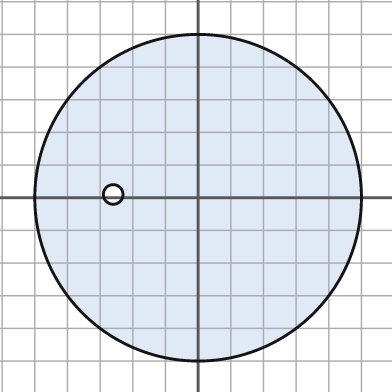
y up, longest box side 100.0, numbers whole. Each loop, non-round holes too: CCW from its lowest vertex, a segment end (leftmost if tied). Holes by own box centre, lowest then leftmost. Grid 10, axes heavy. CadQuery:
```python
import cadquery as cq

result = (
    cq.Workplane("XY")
    .moveTo(0.0, 0.0)
    .circle(50.0)
    .moveTo(-26.0, 1.0)
    .circle(3.0)
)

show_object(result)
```